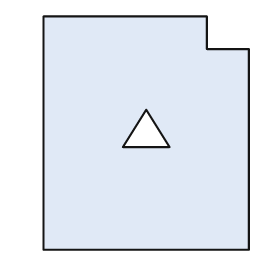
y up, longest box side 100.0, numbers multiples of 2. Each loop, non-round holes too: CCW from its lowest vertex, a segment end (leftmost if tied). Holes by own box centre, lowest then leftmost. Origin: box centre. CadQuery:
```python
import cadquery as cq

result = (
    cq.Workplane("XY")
    .moveTo(-44.0, -50.0)
    .lineTo(44.0, -50.0)
    .lineTo(44.0, 36.0)
    .lineTo(26.0, 36.0)
    .lineTo(26.0, 50.0)
    .lineTo(-44.0, 50.0)
    .close()
    .moveTo(-10.0, -6.0)
    .lineTo(10.0, -6.0)
    .lineTo(0.0, 10.0)
    .close()
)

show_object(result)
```